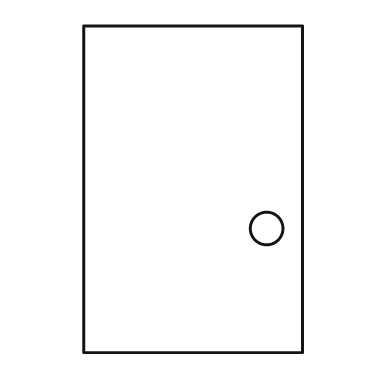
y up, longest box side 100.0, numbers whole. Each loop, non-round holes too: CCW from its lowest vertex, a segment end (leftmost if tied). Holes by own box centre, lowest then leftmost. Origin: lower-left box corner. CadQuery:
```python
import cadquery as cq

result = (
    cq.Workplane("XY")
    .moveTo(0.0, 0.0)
    .lineTo(67.0, 0.0)
    .lineTo(67.0, 100.0)
    .lineTo(0.0, 100.0)
    .close()
    .moveTo(56.0, 38.0)
    .circle(5.0)
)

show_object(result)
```